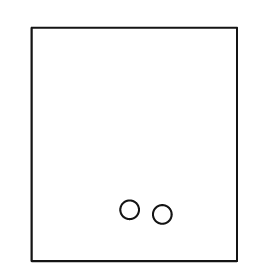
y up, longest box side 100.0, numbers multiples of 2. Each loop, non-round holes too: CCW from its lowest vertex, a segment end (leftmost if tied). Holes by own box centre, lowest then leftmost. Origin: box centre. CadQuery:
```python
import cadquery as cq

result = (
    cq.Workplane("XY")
    .moveTo(-44.0, -50.0)
    .lineTo(44.0, -50.0)
    .lineTo(44.0, 50.0)
    .lineTo(-44.0, 50.0)
    .close()
    .moveTo(12.0, -30.0)
    .circle(4.0)
    .moveTo(-2.0, -28.0)
    .circle(4.0)
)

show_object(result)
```